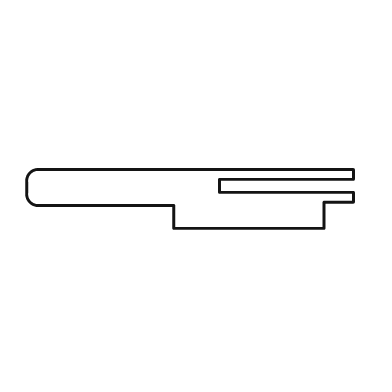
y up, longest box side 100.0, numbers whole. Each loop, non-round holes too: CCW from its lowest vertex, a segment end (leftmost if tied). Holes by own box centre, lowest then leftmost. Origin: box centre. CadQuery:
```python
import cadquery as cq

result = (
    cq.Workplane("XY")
    .moveTo(-5.0, -9.0)
    .lineTo(41.0, -9.0)
    .lineTo(41.0, -1.0)
    .lineTo(50.0, -1.0)
    .lineTo(50.0, 2.0)
    .lineTo(9.0, 2.0)
    .lineTo(9.0, 6.0)
    .lineTo(50.0, 6.0)
    .lineTo(50.0, 9.0)
    .lineTo(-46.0, 9.0)
    .threePointArc((-49.0, 8.0), (-50.0, 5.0))
    .lineTo(-50.0, 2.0)
    .threePointArc((-49.0, -1.0), (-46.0, -2.0))
    .lineTo(-5.0, -2.0)
    .close()
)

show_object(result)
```